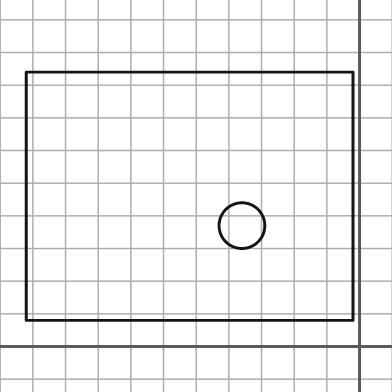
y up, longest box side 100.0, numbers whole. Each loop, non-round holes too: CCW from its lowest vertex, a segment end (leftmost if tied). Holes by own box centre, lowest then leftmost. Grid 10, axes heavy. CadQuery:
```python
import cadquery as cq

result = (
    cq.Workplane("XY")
    .moveTo(-102.0, 8.0)
    .lineTo(-2.0, 8.0)
    .lineTo(-2.0, 84.0)
    .lineTo(-102.0, 84.0)
    .close()
    .moveTo(-36.0, 37.0)
    .circle(7.0)
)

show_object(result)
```